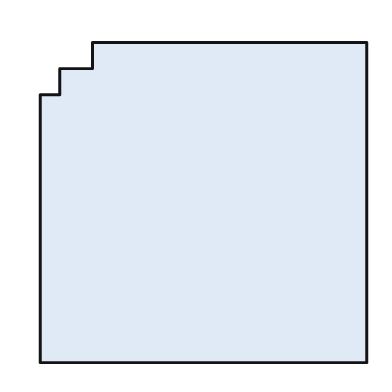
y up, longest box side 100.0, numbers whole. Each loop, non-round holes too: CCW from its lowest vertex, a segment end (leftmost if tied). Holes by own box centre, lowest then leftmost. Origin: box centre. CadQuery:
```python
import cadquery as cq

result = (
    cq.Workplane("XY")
    .moveTo(-50.0, -49.0)
    .lineTo(50.0, -49.0)
    .lineTo(50.0, 49.0)
    .lineTo(-34.0, 49.0)
    .lineTo(-34.0, 41.0)
    .lineTo(-44.0, 41.0)
    .lineTo(-44.0, 33.0)
    .lineTo(-50.0, 33.0)
    .close()
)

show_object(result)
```